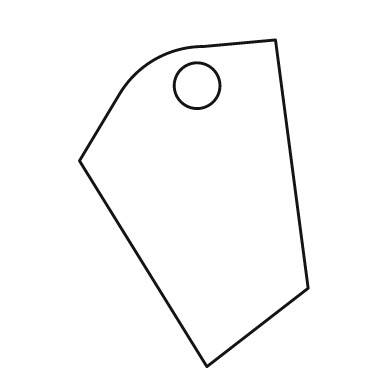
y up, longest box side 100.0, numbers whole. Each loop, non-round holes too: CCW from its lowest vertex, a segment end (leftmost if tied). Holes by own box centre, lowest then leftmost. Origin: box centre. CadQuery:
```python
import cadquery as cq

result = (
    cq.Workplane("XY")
    .moveTo(4.0, -50.0)
    .lineTo(35.0, -26.0)
    .lineTo(25.0, 50.0)
    .lineTo(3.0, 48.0)
    .threePointArc((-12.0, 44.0), (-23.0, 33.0))
    .lineTo(-35.0, 13.0)
    .close()
    .moveTo(1.0, 36.0)
    .circle(7.0)
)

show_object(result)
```